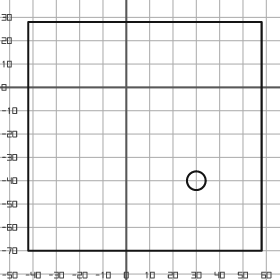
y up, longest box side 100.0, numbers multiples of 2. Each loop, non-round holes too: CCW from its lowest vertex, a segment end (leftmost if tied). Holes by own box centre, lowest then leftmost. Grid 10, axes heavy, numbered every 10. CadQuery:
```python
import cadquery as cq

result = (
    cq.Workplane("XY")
    .moveTo(-42.0, -70.0)
    .lineTo(58.0, -70.0)
    .lineTo(58.0, 28.0)
    .lineTo(-42.0, 28.0)
    .close()
    .moveTo(30.0, -40.0)
    .circle(4.0)
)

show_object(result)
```